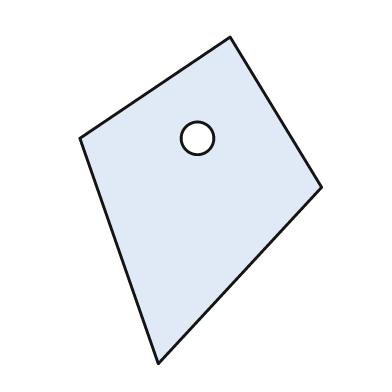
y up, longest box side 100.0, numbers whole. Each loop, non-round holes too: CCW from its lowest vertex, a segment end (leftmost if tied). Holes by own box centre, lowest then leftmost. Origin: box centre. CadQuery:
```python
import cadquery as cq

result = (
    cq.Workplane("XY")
    .moveTo(-13.0, -50.0)
    .lineTo(37.0, 4.0)
    .lineTo(9.0, 50.0)
    .lineTo(-37.0, 19.0)
    .close()
    .moveTo(-1.0, 19.0)
    .circle(5.0)
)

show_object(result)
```